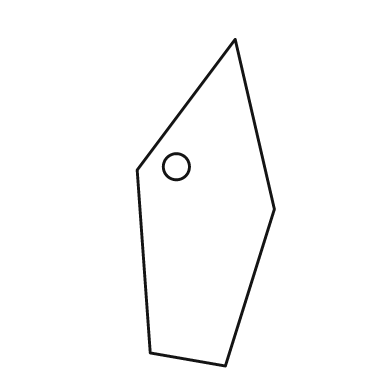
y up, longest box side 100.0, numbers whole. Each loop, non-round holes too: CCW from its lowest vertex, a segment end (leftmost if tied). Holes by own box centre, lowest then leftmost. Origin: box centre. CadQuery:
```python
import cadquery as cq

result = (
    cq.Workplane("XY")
    .moveTo(6.0, -50.0)
    .lineTo(21.0, -2.0)
    .lineTo(9.0, 50.0)
    .lineTo(-21.0, 10.0)
    .lineTo(-17.0, -46.0)
    .close()
    .moveTo(-9.0, 11.0)
    .circle(4.0)
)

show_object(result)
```